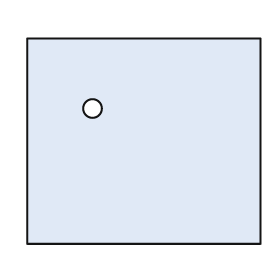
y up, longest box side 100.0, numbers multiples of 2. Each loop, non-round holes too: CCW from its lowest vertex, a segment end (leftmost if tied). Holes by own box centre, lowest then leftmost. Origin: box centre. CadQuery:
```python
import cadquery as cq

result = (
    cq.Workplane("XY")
    .moveTo(-50.0, -44.0)
    .lineTo(50.0, -44.0)
    .lineTo(50.0, 44.0)
    .lineTo(-50.0, 44.0)
    .close()
    .moveTo(-22.0, 14.0)
    .circle(4.0)
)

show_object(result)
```